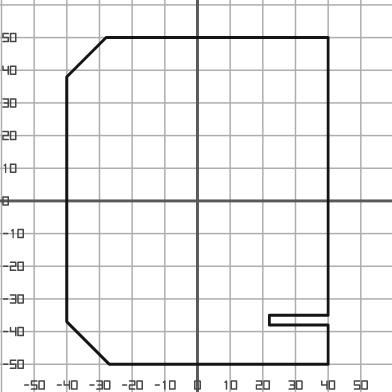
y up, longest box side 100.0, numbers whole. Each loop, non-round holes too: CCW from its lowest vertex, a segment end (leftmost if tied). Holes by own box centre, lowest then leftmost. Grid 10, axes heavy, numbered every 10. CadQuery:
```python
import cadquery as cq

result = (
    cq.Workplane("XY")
    .moveTo(-27.0, -50.0)
    .lineTo(40.0, -50.0)
    .lineTo(40.0, -38.0)
    .lineTo(22.0, -38.0)
    .lineTo(22.0, -35.0)
    .lineTo(40.0, -35.0)
    .lineTo(40.0, 50.0)
    .lineTo(-28.0, 50.0)
    .lineTo(-40.0, 38.0)
    .lineTo(-40.0, -37.0)
    .close()
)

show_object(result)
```